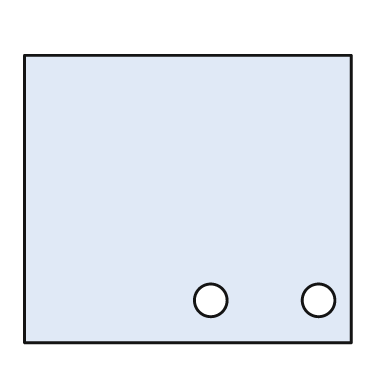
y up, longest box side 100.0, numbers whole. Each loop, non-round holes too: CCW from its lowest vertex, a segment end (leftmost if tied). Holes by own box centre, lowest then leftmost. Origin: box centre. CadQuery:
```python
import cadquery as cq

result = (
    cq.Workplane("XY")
    .moveTo(-50.0, -44.0)
    .lineTo(50.0, -44.0)
    .lineTo(50.0, 44.0)
    .lineTo(-50.0, 44.0)
    .close()
    .moveTo(7.0, -31.0)
    .circle(5.0)
    .moveTo(40.0, -31.0)
    .circle(5.0)
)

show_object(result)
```